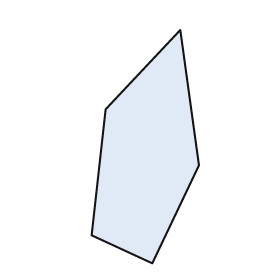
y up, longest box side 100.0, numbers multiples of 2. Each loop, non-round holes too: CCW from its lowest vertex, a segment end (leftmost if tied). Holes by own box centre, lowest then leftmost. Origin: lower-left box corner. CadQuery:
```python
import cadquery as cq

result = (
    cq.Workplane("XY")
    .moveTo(26.0, 0.0)
    .lineTo(46.0, 42.0)
    .lineTo(38.0, 100.0)
    .lineTo(6.0, 66.0)
    .lineTo(0.0, 12.0)
    .close()
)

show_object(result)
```